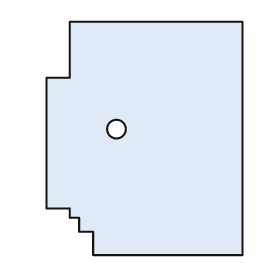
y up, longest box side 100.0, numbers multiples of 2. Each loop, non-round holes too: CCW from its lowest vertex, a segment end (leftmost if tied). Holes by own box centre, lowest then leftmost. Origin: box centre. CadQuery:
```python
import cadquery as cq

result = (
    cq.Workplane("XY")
    .moveTo(-22.0, -50.0)
    .lineTo(42.0, -50.0)
    .lineTo(42.0, 50.0)
    .lineTo(-32.0, 50.0)
    .lineTo(-32.0, 26.0)
    .lineTo(-42.0, 26.0)
    .lineTo(-42.0, -30.0)
    .lineTo(-32.0, -30.0)
    .lineTo(-32.0, -34.0)
    .lineTo(-28.0, -34.0)
    .lineTo(-28.0, -40.0)
    .lineTo(-22.0, -40.0)
    .close()
    .moveTo(-12.0, 4.0)
    .circle(4.0)
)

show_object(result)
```